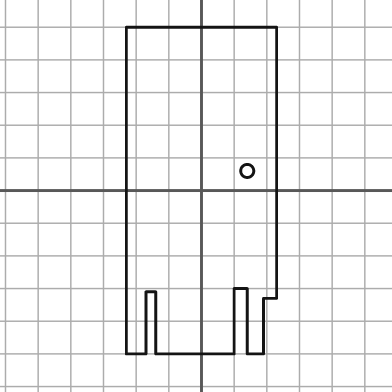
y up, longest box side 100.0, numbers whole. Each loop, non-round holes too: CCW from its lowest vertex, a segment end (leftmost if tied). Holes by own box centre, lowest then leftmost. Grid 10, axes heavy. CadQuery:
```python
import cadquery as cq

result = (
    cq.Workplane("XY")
    .moveTo(-23.0, -50.0)
    .lineTo(-17.0, -50.0)
    .lineTo(-17.0, -31.0)
    .lineTo(-14.0, -31.0)
    .lineTo(-14.0, -50.0)
    .lineTo(10.0, -50.0)
    .lineTo(10.0, -30.0)
    .lineTo(14.0, -30.0)
    .lineTo(14.0, -50.0)
    .lineTo(19.0, -50.0)
    .lineTo(19.0, -33.0)
    .lineTo(23.0, -33.0)
    .lineTo(23.0, 50.0)
    .lineTo(-23.0, 50.0)
    .close()
    .moveTo(14.0, 6.0)
    .circle(2.0)
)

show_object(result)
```